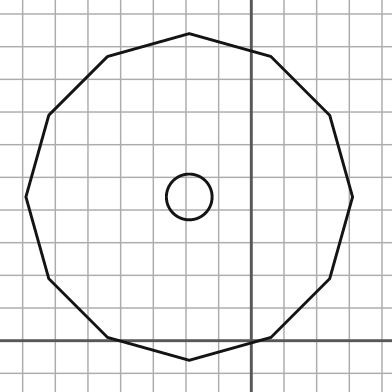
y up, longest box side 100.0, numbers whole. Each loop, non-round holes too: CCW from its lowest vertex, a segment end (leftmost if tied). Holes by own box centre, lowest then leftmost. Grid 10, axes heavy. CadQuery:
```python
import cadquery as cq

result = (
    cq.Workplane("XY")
    .moveTo(-19.0, -6.0)
    .lineTo(6.0, 1.0)
    .lineTo(24.0, 19.0)
    .lineTo(31.0, 44.0)
    .lineTo(24.0, 69.0)
    .lineTo(6.0, 87.0)
    .lineTo(-19.0, 94.0)
    .lineTo(-44.0, 87.0)
    .lineTo(-62.0, 69.0)
    .lineTo(-69.0, 44.0)
    .lineTo(-62.0, 19.0)
    .lineTo(-44.0, 1.0)
    .close()
    .moveTo(-19.0, 44.0)
    .circle(7.0)
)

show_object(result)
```